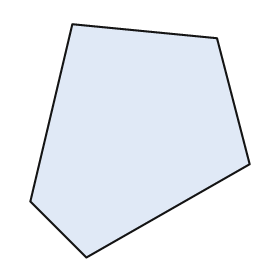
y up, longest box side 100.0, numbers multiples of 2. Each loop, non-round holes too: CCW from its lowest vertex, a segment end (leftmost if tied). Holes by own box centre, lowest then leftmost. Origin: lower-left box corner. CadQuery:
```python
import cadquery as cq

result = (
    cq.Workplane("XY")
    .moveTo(24.0, 0.0)
    .lineTo(94.0, 40.0)
    .lineTo(80.0, 94.0)
    .lineTo(18.0, 100.0)
    .lineTo(0.0, 24.0)
    .close()
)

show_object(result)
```